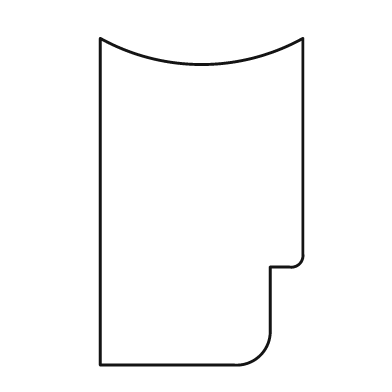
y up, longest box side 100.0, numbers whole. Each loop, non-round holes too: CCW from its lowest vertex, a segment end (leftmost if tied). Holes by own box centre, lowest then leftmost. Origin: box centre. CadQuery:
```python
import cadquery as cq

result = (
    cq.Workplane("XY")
    .moveTo(-31.0, -50.0)
    .lineTo(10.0, -50.0)
    .threePointArc((18.0, -47.0), (21.0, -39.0))
    .lineTo(21.0, -20.0)
    .lineTo(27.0, -20.0)
    .threePointArc((30.0, -19.0), (31.0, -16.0))
    .lineTo(31.0, 50.0)
    .threePointArc((0.0, 42.0), (-31.0, 50.0))
    .close()
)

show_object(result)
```